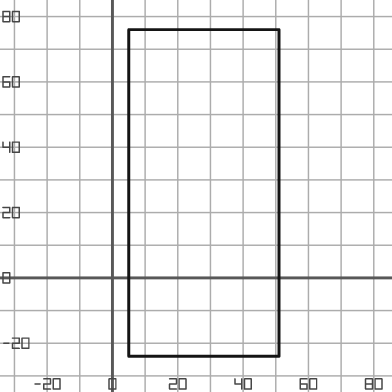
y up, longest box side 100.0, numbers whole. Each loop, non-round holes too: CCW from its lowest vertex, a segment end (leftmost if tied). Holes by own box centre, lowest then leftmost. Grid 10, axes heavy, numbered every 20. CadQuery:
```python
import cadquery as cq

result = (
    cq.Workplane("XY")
    .moveTo(5.0, -24.0)
    .lineTo(51.0, -24.0)
    .lineTo(51.0, 76.0)
    .lineTo(5.0, 76.0)
    .close()
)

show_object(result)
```